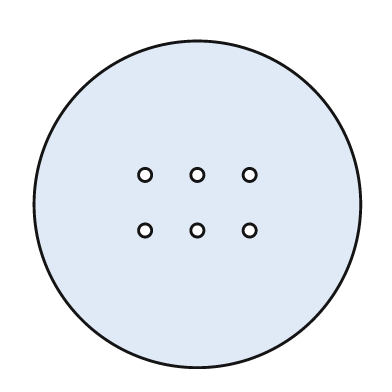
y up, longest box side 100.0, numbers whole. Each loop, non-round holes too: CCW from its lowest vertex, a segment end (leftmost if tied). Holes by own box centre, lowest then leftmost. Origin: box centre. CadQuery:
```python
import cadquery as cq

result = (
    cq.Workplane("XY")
    .moveTo(0.0, 0.0)
    .circle(50.0)
    .moveTo(-16.0, -8.0)
    .circle(2.0)
    .moveTo(0.0, -8.0)
    .circle(2.0)
    .moveTo(16.0, -8.0)
    .circle(2.0)
    .moveTo(-16.0, 9.0)
    .circle(2.0)
    .moveTo(0.0, 9.0)
    .circle(2.0)
    .moveTo(16.0, 9.0)
    .circle(2.0)
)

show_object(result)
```